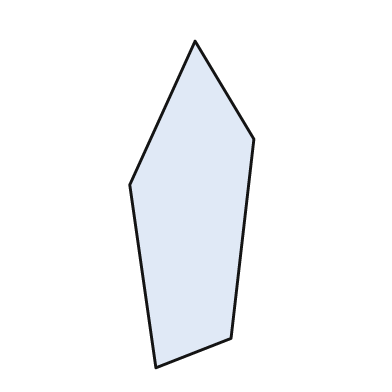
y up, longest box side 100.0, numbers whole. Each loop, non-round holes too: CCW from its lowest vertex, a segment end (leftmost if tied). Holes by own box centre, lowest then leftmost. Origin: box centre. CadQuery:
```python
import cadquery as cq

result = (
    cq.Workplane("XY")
    .moveTo(-11.0, -50.0)
    .lineTo(12.0, -41.0)
    .lineTo(19.0, 20.0)
    .lineTo(1.0, 50.0)
    .lineTo(-19.0, 6.0)
    .close()
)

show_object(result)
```